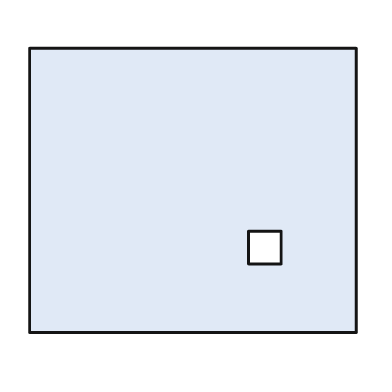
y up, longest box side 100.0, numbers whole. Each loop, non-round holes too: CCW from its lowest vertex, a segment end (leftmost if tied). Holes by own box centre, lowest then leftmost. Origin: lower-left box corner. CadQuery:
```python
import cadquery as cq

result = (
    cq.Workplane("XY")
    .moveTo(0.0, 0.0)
    .lineTo(100.0, 0.0)
    .lineTo(100.0, 87.0)
    .lineTo(0.0, 87.0)
    .close()
    .moveTo(67.0, 21.0)
    .lineTo(77.0, 21.0)
    .lineTo(77.0, 31.0)
    .lineTo(67.0, 31.0)
    .close()
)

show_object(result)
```